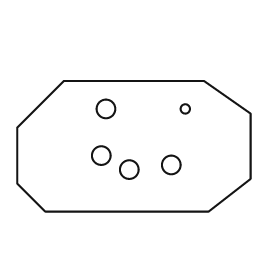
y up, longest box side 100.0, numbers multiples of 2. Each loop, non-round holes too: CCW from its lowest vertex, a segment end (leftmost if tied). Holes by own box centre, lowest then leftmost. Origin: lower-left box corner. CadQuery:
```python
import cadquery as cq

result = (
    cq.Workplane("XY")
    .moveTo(12.0, 0.0)
    .lineTo(82.0, 0.0)
    .lineTo(100.0, 14.0)
    .lineTo(100.0, 42.0)
    .lineTo(80.0, 56.0)
    .lineTo(20.0, 56.0)
    .lineTo(0.0, 36.0)
    .lineTo(0.0, 12.0)
    .close()
    .moveTo(48.0, 18.0)
    .circle(4.0)
    .moveTo(66.0, 20.0)
    .circle(4.0)
    .moveTo(36.0, 24.0)
    .circle(4.0)
    .moveTo(38.0, 44.0)
    .circle(4.0)
    .moveTo(72.0, 44.0)
    .circle(2.0)
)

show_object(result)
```